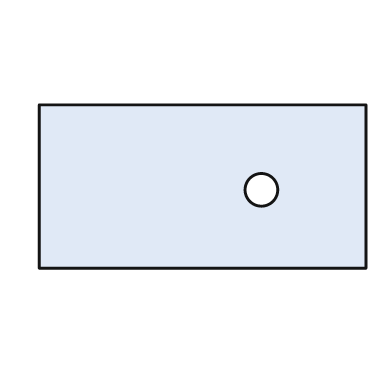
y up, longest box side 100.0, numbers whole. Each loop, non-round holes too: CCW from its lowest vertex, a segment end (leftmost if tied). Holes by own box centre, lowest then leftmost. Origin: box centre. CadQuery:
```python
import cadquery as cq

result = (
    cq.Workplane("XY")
    .moveTo(-50.0, -25.0)
    .lineTo(50.0, -25.0)
    .lineTo(50.0, 25.0)
    .lineTo(-50.0, 25.0)
    .close()
    .moveTo(18.0, -1.0)
    .circle(5.0)
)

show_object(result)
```